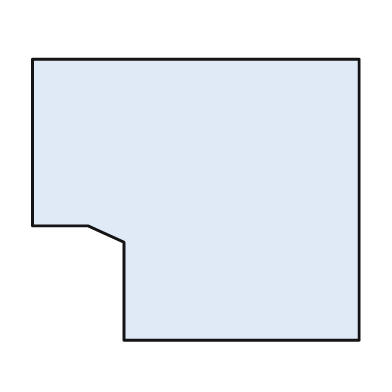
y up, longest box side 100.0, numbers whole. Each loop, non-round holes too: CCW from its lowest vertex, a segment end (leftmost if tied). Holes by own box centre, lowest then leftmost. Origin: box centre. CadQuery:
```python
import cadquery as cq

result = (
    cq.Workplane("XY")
    .moveTo(-22.0, -43.0)
    .lineTo(50.0, -43.0)
    .lineTo(50.0, 43.0)
    .lineTo(-50.0, 43.0)
    .lineTo(-50.0, -8.0)
    .lineTo(-33.0, -8.0)
    .lineTo(-22.0, -13.0)
    .close()
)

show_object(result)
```